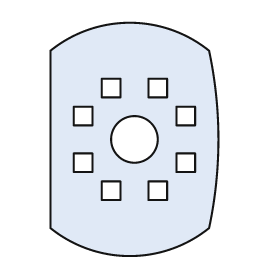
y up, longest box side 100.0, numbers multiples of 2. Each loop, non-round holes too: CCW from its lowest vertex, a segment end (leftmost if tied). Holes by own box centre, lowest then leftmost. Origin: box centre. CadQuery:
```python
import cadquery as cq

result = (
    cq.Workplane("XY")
    .moveTo(-36.0, -38.0)
    .threePointArc((-2.0, -50.0), (32.0, -38.0))
    .threePointArc((36.0, 0.0), (32.0, 38.0))
    .threePointArc((-2.0, 50.0), (-36.0, 38.0))
    .close()
    .moveTo(-14.0, -26.0)
    .lineTo(-6.0, -26.0)
    .lineTo(-6.0, -18.0)
    .lineTo(-14.0, -18.0)
    .close()
    .moveTo(6.0, -26.0)
    .lineTo(14.0, -26.0)
    .lineTo(14.0, -18.0)
    .lineTo(6.0, -18.0)
    .close()
    .moveTo(-26.0, -14.0)
    .lineTo(-18.0, -14.0)
    .lineTo(-18.0, -6.0)
    .lineTo(-26.0, -6.0)
    .close()
    .moveTo(18.0, -14.0)
    .lineTo(26.0, -14.0)
    .lineTo(26.0, -6.0)
    .lineTo(18.0, -6.0)
    .close()
    .moveTo(0.0, 0.0)
    .circle(10.0)
    .moveTo(-26.0, 6.0)
    .lineTo(-18.0, 6.0)
    .lineTo(-18.0, 14.0)
    .lineTo(-26.0, 14.0)
    .close()
    .moveTo(18.0, 6.0)
    .lineTo(26.0, 6.0)
    .lineTo(26.0, 14.0)
    .lineTo(18.0, 14.0)
    .close()
    .moveTo(-14.0, 18.0)
    .lineTo(-6.0, 18.0)
    .lineTo(-6.0, 26.0)
    .lineTo(-14.0, 26.0)
    .close()
    .moveTo(6.0, 18.0)
    .lineTo(14.0, 18.0)
    .lineTo(14.0, 26.0)
    .lineTo(6.0, 26.0)
    .close()
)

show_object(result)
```